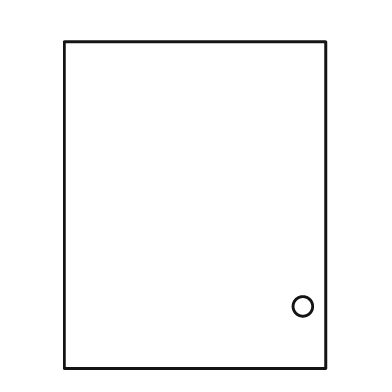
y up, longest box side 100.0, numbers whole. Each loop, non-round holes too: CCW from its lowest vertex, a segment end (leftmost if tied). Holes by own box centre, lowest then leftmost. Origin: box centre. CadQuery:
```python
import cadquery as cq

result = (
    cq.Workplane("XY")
    .moveTo(-40.0, -50.0)
    .lineTo(40.0, -50.0)
    .lineTo(40.0, 50.0)
    .lineTo(-40.0, 50.0)
    .close()
    .moveTo(33.0, -31.0)
    .circle(3.0)
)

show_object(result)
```